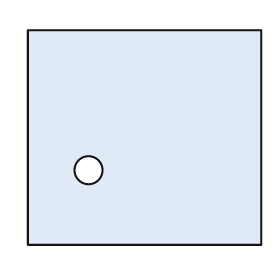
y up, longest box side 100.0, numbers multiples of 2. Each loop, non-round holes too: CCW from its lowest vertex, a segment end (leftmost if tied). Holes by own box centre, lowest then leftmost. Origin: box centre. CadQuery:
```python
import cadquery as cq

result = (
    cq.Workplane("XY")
    .moveTo(-50.0, -46.0)
    .lineTo(50.0, -46.0)
    .lineTo(50.0, 46.0)
    .lineTo(-50.0, 46.0)
    .close()
    .moveTo(-24.0, -14.0)
    .circle(6.0)
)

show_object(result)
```